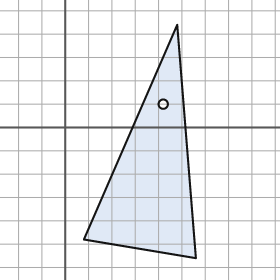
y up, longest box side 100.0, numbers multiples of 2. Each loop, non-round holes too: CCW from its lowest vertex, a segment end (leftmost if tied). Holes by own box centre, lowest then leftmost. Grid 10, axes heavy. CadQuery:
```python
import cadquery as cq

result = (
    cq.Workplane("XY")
    .moveTo(56.0, -56.0)
    .lineTo(48.0, 44.0)
    .lineTo(8.0, -48.0)
    .close()
    .moveTo(42.0, 10.0)
    .circle(2.0)
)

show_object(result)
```